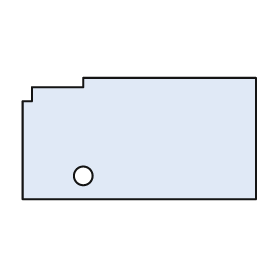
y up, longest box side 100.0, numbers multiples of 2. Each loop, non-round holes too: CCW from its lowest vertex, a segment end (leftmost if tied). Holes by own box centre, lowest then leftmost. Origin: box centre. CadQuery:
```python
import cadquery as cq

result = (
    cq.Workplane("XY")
    .moveTo(-50.0, -26.0)
    .lineTo(50.0, -26.0)
    .lineTo(50.0, 26.0)
    .lineTo(-24.0, 26.0)
    .lineTo(-24.0, 22.0)
    .lineTo(-46.0, 22.0)
    .lineTo(-46.0, 16.0)
    .lineTo(-50.0, 16.0)
    .close()
    .moveTo(-24.0, -16.0)
    .circle(4.0)
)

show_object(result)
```